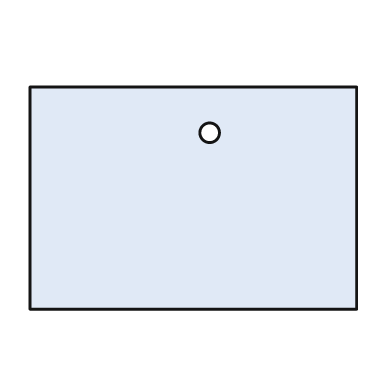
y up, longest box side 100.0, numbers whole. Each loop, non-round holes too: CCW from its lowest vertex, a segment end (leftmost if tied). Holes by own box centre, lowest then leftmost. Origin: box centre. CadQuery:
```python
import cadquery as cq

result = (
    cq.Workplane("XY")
    .moveTo(-50.0, -34.0)
    .lineTo(50.0, -34.0)
    .lineTo(50.0, 34.0)
    .lineTo(-50.0, 34.0)
    .close()
    .moveTo(5.0, 20.0)
    .circle(3.0)
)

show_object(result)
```